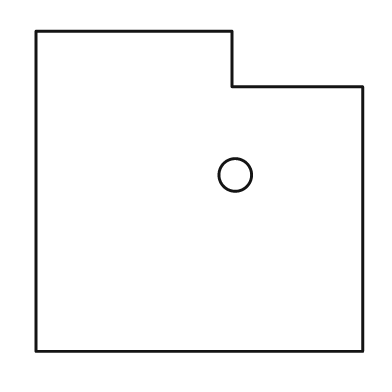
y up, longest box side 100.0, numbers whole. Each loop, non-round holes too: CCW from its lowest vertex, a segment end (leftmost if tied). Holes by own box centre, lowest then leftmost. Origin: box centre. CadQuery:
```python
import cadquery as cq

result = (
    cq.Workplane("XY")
    .moveTo(-50.0, -49.0)
    .lineTo(50.0, -49.0)
    .lineTo(50.0, 32.0)
    .lineTo(10.0, 32.0)
    .lineTo(10.0, 49.0)
    .lineTo(-50.0, 49.0)
    .close()
    .moveTo(11.0, 5.0)
    .circle(5.0)
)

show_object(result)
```